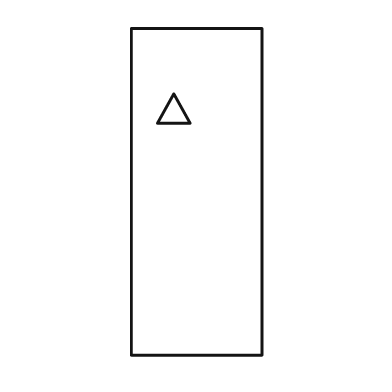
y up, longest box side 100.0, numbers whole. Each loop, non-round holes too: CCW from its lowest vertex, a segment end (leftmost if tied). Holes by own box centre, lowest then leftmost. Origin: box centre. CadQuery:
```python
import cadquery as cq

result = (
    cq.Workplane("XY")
    .moveTo(-20.0, -50.0)
    .lineTo(20.0, -50.0)
    .lineTo(20.0, 50.0)
    .lineTo(-20.0, 50.0)
    .close()
    .moveTo(-12.0, 21.0)
    .lineTo(-2.0, 21.0)
    .lineTo(-7.0, 30.0)
    .close()
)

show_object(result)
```